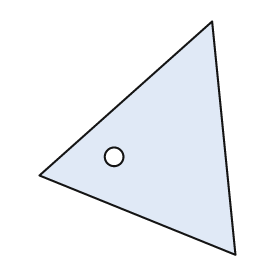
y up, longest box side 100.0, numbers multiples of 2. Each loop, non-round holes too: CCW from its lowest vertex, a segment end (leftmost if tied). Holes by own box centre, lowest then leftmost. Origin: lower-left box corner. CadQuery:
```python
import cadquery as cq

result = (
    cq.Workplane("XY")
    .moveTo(84.0, 0.0)
    .lineTo(74.0, 100.0)
    .lineTo(0.0, 34.0)
    .close()
    .moveTo(32.0, 42.0)
    .circle(4.0)
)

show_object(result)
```